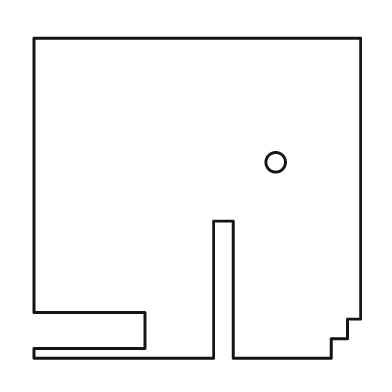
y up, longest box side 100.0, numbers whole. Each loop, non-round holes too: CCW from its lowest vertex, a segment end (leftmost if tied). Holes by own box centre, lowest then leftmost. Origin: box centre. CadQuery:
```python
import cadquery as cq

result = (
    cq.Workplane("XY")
    .moveTo(-50.0, -49.0)
    .lineTo(5.0, -49.0)
    .lineTo(5.0, -7.0)
    .lineTo(11.0, -7.0)
    .lineTo(11.0, -49.0)
    .lineTo(41.0, -49.0)
    .lineTo(41.0, -43.0)
    .lineTo(46.0, -43.0)
    .lineTo(46.0, -37.0)
    .lineTo(50.0, -37.0)
    .lineTo(50.0, 49.0)
    .lineTo(-50.0, 49.0)
    .lineTo(-50.0, -35.0)
    .lineTo(-16.0, -35.0)
    .lineTo(-16.0, -46.0)
    .lineTo(-50.0, -46.0)
    .close()
    .moveTo(24.0, 11.0)
    .circle(3.0)
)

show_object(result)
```